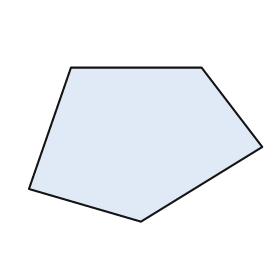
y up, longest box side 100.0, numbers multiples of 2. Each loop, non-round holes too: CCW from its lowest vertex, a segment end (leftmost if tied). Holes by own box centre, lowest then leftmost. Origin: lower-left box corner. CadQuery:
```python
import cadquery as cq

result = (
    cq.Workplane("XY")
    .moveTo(48.0, 0.0)
    .lineTo(100.0, 32.0)
    .lineTo(74.0, 66.0)
    .lineTo(18.0, 66.0)
    .lineTo(0.0, 14.0)
    .close()
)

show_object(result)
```